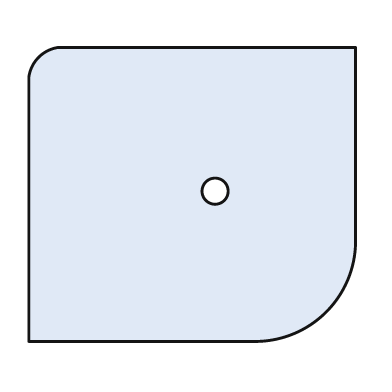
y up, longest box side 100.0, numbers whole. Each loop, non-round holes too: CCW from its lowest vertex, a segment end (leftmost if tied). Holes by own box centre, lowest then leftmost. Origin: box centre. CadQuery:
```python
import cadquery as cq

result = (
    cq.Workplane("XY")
    .moveTo(-50.0, -45.0)
    .lineTo(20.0, -45.0)
    .threePointArc((41.0, -36.0), (50.0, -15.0))
    .lineTo(50.0, 45.0)
    .lineTo(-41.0, 45.0)
    .threePointArc((-47.0, 42.0), (-50.0, 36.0))
    .close()
    .moveTo(7.0, 1.0)
    .circle(4.0)
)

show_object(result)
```